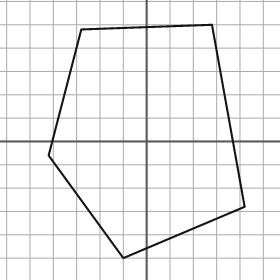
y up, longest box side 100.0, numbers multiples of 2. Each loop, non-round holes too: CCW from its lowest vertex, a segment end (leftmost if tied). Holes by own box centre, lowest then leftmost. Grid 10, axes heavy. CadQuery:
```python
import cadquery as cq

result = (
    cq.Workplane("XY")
    .moveTo(-10.0, -50.0)
    .lineTo(42.0, -28.0)
    .lineTo(28.0, 50.0)
    .lineTo(-28.0, 48.0)
    .lineTo(-42.0, -6.0)
    .close()
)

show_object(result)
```